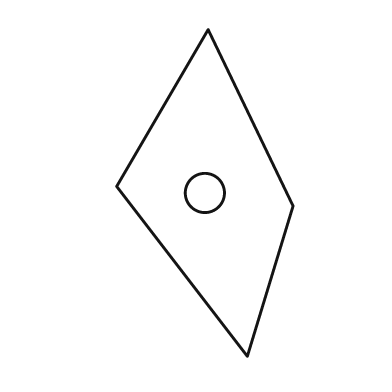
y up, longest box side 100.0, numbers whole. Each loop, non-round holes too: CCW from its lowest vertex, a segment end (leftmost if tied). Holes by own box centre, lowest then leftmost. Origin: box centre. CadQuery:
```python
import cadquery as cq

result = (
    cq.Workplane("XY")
    .moveTo(13.0, -50.0)
    .lineTo(27.0, -4.0)
    .lineTo(1.0, 50.0)
    .lineTo(-27.0, 2.0)
    .close()
    .moveTo(0.0, 0.0)
    .circle(6.0)
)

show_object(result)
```